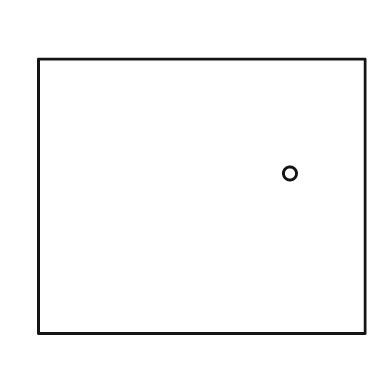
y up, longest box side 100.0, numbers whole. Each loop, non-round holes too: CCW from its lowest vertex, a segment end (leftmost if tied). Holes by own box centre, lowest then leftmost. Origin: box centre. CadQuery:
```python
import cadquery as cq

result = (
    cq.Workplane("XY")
    .moveTo(-50.0, -42.0)
    .lineTo(50.0, -42.0)
    .lineTo(50.0, 42.0)
    .lineTo(-50.0, 42.0)
    .close()
    .moveTo(27.0, 7.0)
    .circle(2.0)
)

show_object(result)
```